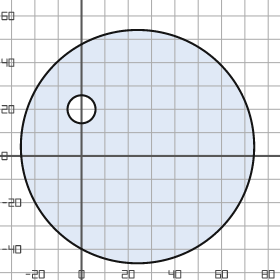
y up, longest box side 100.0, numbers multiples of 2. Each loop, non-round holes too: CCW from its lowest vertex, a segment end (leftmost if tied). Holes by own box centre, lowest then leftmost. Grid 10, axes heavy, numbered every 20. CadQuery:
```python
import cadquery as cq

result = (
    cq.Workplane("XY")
    .moveTo(24.0, 4.0)
    .circle(50.0)
    .moveTo(0.0, 20.0)
    .circle(6.0)
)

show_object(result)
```